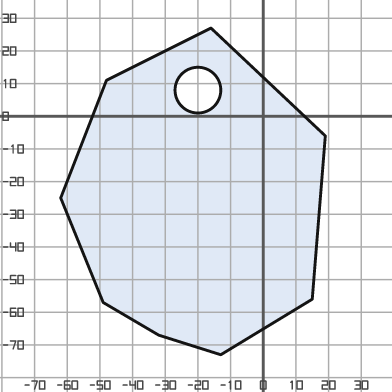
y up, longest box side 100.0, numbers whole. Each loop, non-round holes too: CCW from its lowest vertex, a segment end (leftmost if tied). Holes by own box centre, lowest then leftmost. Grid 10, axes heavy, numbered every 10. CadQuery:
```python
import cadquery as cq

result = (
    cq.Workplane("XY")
    .moveTo(-13.0, -73.0)
    .lineTo(15.0, -56.0)
    .lineTo(19.0, -6.0)
    .lineTo(-16.0, 27.0)
    .lineTo(-48.0, 11.0)
    .lineTo(-62.0, -25.0)
    .lineTo(-49.0, -57.0)
    .lineTo(-32.0, -67.0)
    .close()
    .moveTo(-20.0, 8.0)
    .circle(7.0)
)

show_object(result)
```